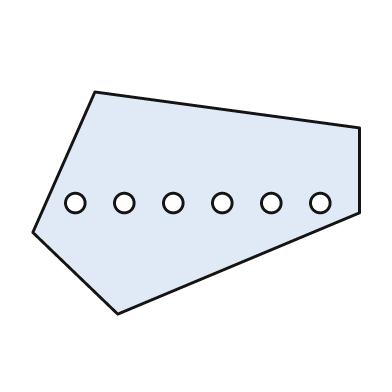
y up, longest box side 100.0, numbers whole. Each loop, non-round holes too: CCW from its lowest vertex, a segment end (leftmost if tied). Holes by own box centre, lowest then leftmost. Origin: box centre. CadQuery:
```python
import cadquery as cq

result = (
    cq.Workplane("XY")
    .moveTo(-24.0, -34.0)
    .lineTo(50.0, -3.0)
    .lineTo(50.0, 23.0)
    .lineTo(-31.0, 34.0)
    .lineTo(-50.0, -9.0)
    .close()
    .moveTo(-37.0, 0.0)
    .circle(3.0)
    .moveTo(-22.0, 0.0)
    .circle(3.0)
    .moveTo(-7.0, 0.0)
    .circle(3.0)
    .moveTo(8.0, 0.0)
    .circle(3.0)
    .moveTo(23.0, 0.0)
    .circle(3.0)
    .moveTo(38.0, 0.0)
    .circle(3.0)
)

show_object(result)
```